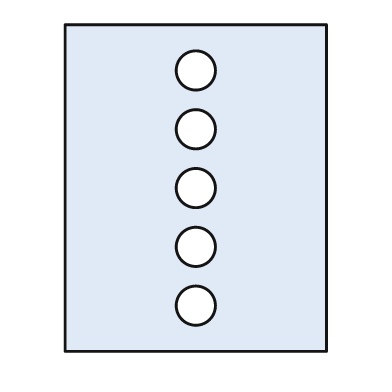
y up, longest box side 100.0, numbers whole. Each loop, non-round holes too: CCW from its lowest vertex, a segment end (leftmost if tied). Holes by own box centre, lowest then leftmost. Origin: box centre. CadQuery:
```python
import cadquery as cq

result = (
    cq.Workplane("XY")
    .moveTo(-40.0, -50.0)
    .lineTo(40.0, -50.0)
    .lineTo(40.0, 50.0)
    .lineTo(-40.0, 50.0)
    .close()
    .moveTo(0.0, -36.0)
    .circle(6.0)
    .moveTo(0.0, -18.0)
    .circle(6.0)
    .moveTo(0.0, 0.0)
    .circle(6.0)
    .moveTo(0.0, 18.0)
    .circle(6.0)
    .moveTo(0.0, 36.0)
    .circle(6.0)
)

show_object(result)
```